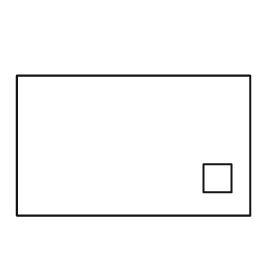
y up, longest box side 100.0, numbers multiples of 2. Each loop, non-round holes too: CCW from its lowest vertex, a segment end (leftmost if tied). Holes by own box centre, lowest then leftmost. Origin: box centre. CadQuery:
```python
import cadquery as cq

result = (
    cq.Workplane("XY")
    .moveTo(-50.0, -30.0)
    .lineTo(50.0, -30.0)
    .lineTo(50.0, 30.0)
    .lineTo(-50.0, 30.0)
    .close()
    .moveTo(30.0, -20.0)
    .lineTo(42.0, -20.0)
    .lineTo(42.0, -8.0)
    .lineTo(30.0, -8.0)
    .close()
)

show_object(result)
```